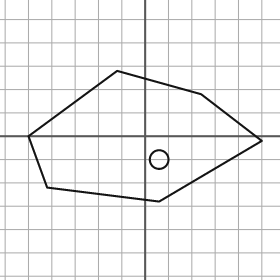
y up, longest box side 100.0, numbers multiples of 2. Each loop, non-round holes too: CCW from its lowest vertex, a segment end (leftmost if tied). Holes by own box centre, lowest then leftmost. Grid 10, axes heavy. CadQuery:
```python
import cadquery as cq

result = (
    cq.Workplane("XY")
    .moveTo(6.0, -28.0)
    .lineTo(50.0, -2.0)
    .lineTo(24.0, 18.0)
    .lineTo(-12.0, 28.0)
    .lineTo(-50.0, 0.0)
    .lineTo(-42.0, -22.0)
    .close()
    .moveTo(6.0, -10.0)
    .circle(4.0)
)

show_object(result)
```